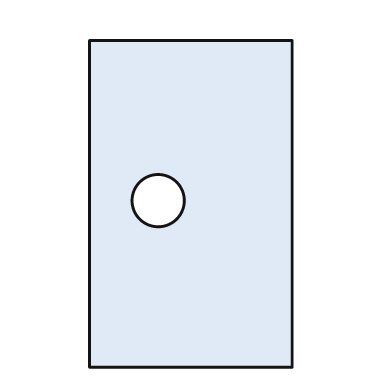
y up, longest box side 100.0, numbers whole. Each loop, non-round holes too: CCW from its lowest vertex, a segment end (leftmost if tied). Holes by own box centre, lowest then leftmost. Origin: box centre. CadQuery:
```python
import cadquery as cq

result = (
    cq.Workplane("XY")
    .moveTo(-31.0, -50.0)
    .lineTo(31.0, -50.0)
    .lineTo(31.0, 50.0)
    .lineTo(-31.0, 50.0)
    .close()
    .moveTo(-10.0, 1.0)
    .circle(8.0)
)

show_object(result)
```